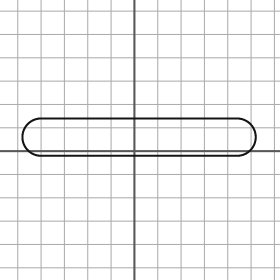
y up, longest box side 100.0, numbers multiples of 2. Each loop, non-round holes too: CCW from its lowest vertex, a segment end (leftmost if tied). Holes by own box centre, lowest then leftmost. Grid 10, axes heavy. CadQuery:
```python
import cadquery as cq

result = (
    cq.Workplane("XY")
    .moveTo(-40.0, -2.0)
    .lineTo(44.0, -2.0)
    .threePointArc((52.0, 6.0), (44.0, 14.0))
    .lineTo(-40.0, 14.0)
    .threePointArc((-48.0, 6.0), (-40.0, -2.0))
    .close()
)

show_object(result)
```